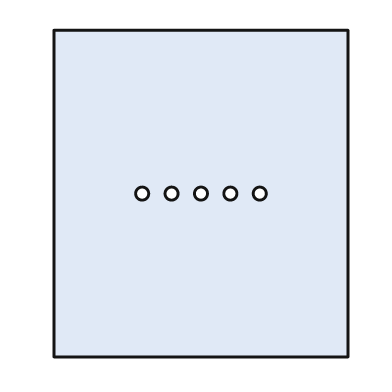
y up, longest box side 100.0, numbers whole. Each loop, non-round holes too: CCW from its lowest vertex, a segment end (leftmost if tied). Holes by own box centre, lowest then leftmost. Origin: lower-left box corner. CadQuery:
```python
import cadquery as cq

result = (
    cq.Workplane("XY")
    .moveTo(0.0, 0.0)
    .lineTo(90.0, 0.0)
    .lineTo(90.0, 100.0)
    .lineTo(0.0, 100.0)
    .close()
    .moveTo(27.0, 50.0)
    .circle(2.0)
    .moveTo(36.0, 50.0)
    .circle(2.0)
    .moveTo(45.0, 50.0)
    .circle(2.0)
    .moveTo(54.0, 50.0)
    .circle(2.0)
    .moveTo(63.0, 50.0)
    .circle(2.0)
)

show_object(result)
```